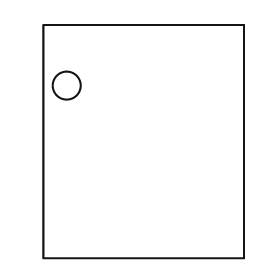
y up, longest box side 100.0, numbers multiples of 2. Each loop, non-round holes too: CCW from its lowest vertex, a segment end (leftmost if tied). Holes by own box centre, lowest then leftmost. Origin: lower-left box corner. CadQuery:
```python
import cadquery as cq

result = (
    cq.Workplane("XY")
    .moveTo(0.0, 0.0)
    .lineTo(86.0, 0.0)
    .lineTo(86.0, 100.0)
    .lineTo(0.0, 100.0)
    .close()
    .moveTo(10.0, 74.0)
    .circle(6.0)
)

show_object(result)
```